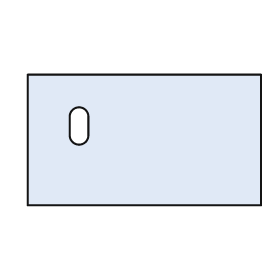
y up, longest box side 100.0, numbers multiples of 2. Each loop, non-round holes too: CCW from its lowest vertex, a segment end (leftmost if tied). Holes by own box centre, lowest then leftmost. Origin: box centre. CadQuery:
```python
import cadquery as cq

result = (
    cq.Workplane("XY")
    .moveTo(-50.0, -28.0)
    .lineTo(50.0, -28.0)
    .lineTo(50.0, 28.0)
    .lineTo(-50.0, 28.0)
    .close()
    .moveTo(-32.0, 2.0)
    .threePointArc((-28.0, -2.0), (-24.0, 2.0))
    .lineTo(-24.0, 10.0)
    .threePointArc((-28.0, 14.0), (-32.0, 10.0))
    .close()
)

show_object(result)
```